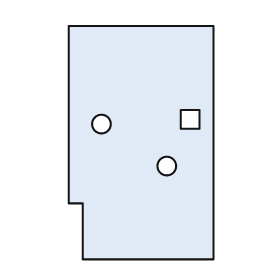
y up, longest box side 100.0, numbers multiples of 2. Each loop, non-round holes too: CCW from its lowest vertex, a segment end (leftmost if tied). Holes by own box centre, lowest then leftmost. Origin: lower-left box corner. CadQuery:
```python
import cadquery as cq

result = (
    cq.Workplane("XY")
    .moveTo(6.0, 0.0)
    .lineTo(62.0, 0.0)
    .lineTo(62.0, 100.0)
    .lineTo(0.0, 100.0)
    .lineTo(0.0, 24.0)
    .lineTo(6.0, 24.0)
    .close()
    .moveTo(42.0, 40.0)
    .circle(4.0)
    .moveTo(14.0, 58.0)
    .circle(4.0)
    .moveTo(48.0, 56.0)
    .lineTo(56.0, 56.0)
    .lineTo(56.0, 64.0)
    .lineTo(48.0, 64.0)
    .close()
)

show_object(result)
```